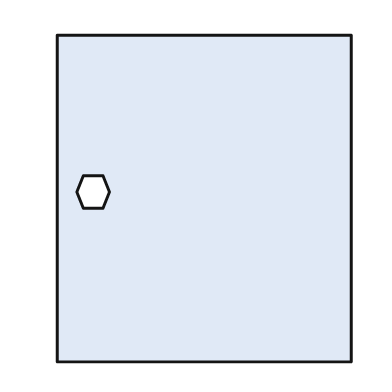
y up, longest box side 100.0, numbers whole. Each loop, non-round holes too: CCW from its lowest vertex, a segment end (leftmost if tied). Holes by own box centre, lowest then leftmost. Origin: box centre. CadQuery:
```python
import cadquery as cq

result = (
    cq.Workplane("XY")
    .moveTo(-45.0, -50.0)
    .lineTo(45.0, -50.0)
    .lineTo(45.0, 50.0)
    .lineTo(-45.0, 50.0)
    .close()
    .moveTo(-37.0, -3.0)
    .lineTo(-31.0, -3.0)
    .lineTo(-29.0, 2.0)
    .lineTo(-31.0, 7.0)
    .lineTo(-37.0, 7.0)
    .lineTo(-39.0, 2.0)
    .close()
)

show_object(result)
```